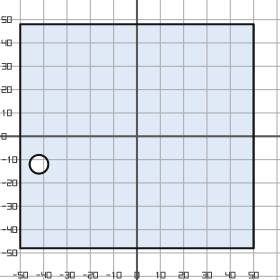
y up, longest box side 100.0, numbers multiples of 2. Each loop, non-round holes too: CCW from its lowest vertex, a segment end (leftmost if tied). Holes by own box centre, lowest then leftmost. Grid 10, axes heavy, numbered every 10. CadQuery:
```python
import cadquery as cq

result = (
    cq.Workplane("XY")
    .moveTo(-50.0, -48.0)
    .lineTo(50.0, -48.0)
    .lineTo(50.0, 48.0)
    .lineTo(-50.0, 48.0)
    .close()
    .moveTo(-42.0, -12.0)
    .circle(4.0)
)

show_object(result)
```